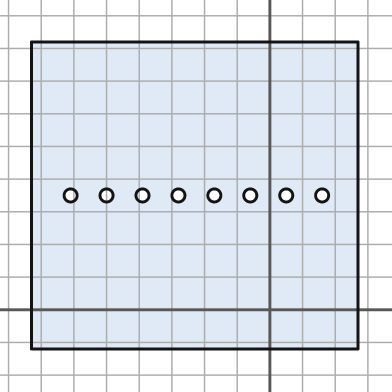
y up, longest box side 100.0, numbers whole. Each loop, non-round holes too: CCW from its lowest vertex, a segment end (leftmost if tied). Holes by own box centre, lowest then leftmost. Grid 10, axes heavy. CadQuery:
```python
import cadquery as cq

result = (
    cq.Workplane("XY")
    .moveTo(-73.0, -12.0)
    .lineTo(27.0, -12.0)
    .lineTo(27.0, 82.0)
    .lineTo(-73.0, 82.0)
    .close()
    .moveTo(-61.0, 35.0)
    .circle(2.0)
    .moveTo(-50.0, 35.0)
    .circle(2.0)
    .moveTo(-39.0, 35.0)
    .circle(2.0)
    .moveTo(-28.0, 35.0)
    .circle(2.0)
    .moveTo(-17.0, 35.0)
    .circle(2.0)
    .moveTo(-6.0, 35.0)
    .circle(2.0)
    .moveTo(5.0, 35.0)
    .circle(2.0)
    .moveTo(16.0, 35.0)
    .circle(2.0)
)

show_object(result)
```